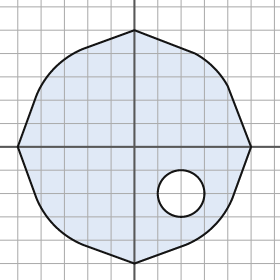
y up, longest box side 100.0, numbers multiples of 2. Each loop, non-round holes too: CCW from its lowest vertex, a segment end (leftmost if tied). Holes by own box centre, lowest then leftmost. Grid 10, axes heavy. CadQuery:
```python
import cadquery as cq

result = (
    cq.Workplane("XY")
    .moveTo(0.0, -50.0)
    .lineTo(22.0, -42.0)
    .threePointArc((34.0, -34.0), (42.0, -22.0))
    .lineTo(50.0, 0.0)
    .lineTo(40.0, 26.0)
    .threePointArc((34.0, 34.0), (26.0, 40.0))
    .lineTo(0.0, 50.0)
    .lineTo(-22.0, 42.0)
    .threePointArc((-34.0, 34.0), (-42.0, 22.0))
    .lineTo(-50.0, 0.0)
    .lineTo(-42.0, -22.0)
    .threePointArc((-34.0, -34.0), (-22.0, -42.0))
    .close()
    .moveTo(20.0, -20.0)
    .circle(10.0)
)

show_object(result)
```